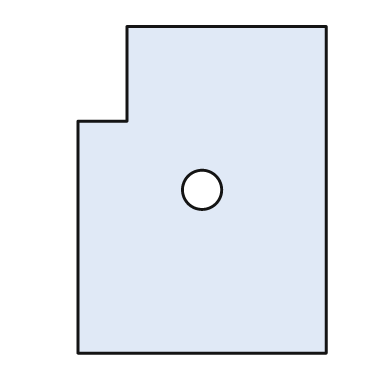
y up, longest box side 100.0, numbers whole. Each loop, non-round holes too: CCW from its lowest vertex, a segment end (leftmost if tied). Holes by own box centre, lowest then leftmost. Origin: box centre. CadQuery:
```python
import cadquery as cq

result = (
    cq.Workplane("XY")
    .moveTo(-38.0, -50.0)
    .lineTo(38.0, -50.0)
    .lineTo(38.0, 50.0)
    .lineTo(-23.0, 50.0)
    .lineTo(-23.0, 21.0)
    .lineTo(-38.0, 21.0)
    .close()
    .moveTo(0.0, 0.0)
    .circle(6.0)
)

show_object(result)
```